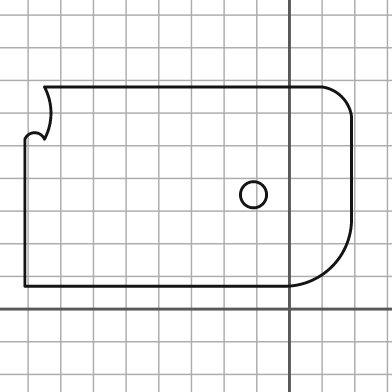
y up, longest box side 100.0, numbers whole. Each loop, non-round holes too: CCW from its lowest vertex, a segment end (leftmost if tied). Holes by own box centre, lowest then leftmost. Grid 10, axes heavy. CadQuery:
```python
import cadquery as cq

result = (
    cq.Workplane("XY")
    .moveTo(-81.0, 7.0)
    .lineTo(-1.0, 7.0)
    .threePointArc((13.0, 13.0), (19.0, 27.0))
    .lineTo(19.0, 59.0)
    .threePointArc((16.0, 65.0), (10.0, 68.0))
    .lineTo(-75.0, 68.0)
    .threePointArc((-73.0, 60.0), (-75.0, 52.0))
    .threePointArc((-78.0, 54.0), (-81.0, 52.0))
    .close()
    .moveTo(-11.0, 35.0)
    .circle(4.0)
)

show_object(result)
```